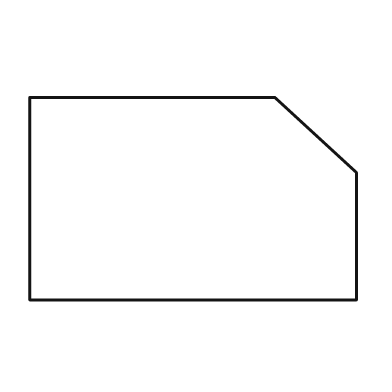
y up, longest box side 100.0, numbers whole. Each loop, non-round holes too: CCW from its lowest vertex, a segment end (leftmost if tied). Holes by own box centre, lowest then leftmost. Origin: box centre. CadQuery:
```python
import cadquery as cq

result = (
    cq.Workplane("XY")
    .moveTo(-50.0, -31.0)
    .lineTo(50.0, -31.0)
    .lineTo(50.0, 8.0)
    .lineTo(25.0, 31.0)
    .lineTo(-50.0, 31.0)
    .close()
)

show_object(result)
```